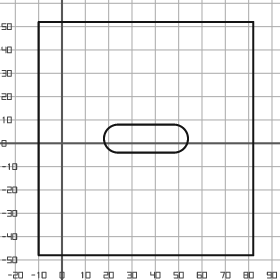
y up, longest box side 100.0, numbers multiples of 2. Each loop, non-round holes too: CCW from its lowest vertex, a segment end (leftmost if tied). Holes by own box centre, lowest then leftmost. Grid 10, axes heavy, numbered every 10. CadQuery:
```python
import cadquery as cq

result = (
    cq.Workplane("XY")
    .moveTo(-10.0, -48.0)
    .lineTo(82.0, -48.0)
    .lineTo(82.0, 52.0)
    .lineTo(-10.0, 52.0)
    .close()
    .moveTo(24.0, -4.0)
    .lineTo(48.0, -4.0)
    .threePointArc((54.0, 2.0), (48.0, 8.0))
    .lineTo(24.0, 8.0)
    .threePointArc((18.0, 2.0), (24.0, -4.0))
    .close()
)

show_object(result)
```